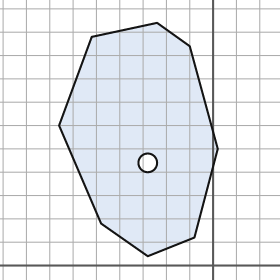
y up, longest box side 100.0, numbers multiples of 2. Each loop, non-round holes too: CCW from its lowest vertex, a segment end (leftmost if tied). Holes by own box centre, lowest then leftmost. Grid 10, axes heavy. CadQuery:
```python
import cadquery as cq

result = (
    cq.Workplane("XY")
    .moveTo(-28.0, 4.0)
    .lineTo(-8.0, 12.0)
    .lineTo(2.0, 50.0)
    .lineTo(-10.0, 94.0)
    .lineTo(-24.0, 104.0)
    .lineTo(-52.0, 98.0)
    .lineTo(-66.0, 60.0)
    .lineTo(-48.0, 18.0)
    .close()
    .moveTo(-28.0, 44.0)
    .circle(4.0)
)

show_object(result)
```